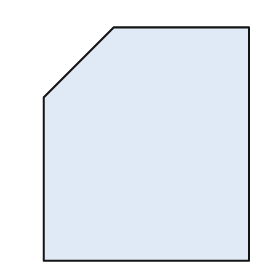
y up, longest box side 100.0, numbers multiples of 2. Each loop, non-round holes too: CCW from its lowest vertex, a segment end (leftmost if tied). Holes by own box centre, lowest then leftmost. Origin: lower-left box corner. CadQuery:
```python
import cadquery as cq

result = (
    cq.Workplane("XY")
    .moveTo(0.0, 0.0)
    .lineTo(88.0, 0.0)
    .lineTo(88.0, 100.0)
    .lineTo(30.0, 100.0)
    .lineTo(0.0, 70.0)
    .close()
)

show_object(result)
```